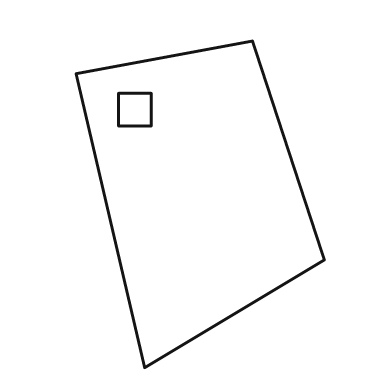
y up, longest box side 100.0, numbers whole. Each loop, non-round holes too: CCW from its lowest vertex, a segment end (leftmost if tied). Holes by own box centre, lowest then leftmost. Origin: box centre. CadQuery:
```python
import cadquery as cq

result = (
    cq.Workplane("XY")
    .moveTo(-17.0, -50.0)
    .lineTo(38.0, -17.0)
    .lineTo(16.0, 50.0)
    .lineTo(-38.0, 40.0)
    .close()
    .moveTo(-25.0, 24.0)
    .lineTo(-15.0, 24.0)
    .lineTo(-15.0, 34.0)
    .lineTo(-25.0, 34.0)
    .close()
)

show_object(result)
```